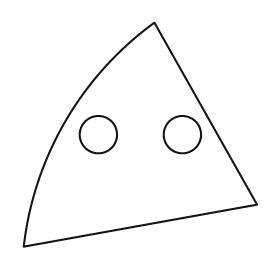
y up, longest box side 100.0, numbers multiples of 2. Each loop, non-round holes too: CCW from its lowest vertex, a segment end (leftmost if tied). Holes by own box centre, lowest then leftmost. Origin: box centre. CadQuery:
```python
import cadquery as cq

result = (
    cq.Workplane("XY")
    .moveTo(-50.0, -48.0)
    .lineTo(50.0, -30.0)
    .lineTo(6.0, 48.0)
    .threePointArc((-32.0, 6.0), (-50.0, -48.0))
    .close()
    .moveTo(-18.0, 0.0)
    .circle(8.0)
    .moveTo(18.0, 0.0)
    .circle(8.0)
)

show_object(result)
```